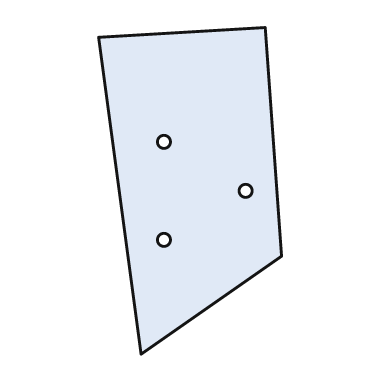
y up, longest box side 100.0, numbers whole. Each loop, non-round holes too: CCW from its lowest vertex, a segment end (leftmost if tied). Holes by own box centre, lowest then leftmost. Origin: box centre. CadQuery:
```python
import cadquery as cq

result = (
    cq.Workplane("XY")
    .moveTo(-15.0, -50.0)
    .lineTo(28.0, -20.0)
    .lineTo(23.0, 50.0)
    .lineTo(-28.0, 47.0)
    .close()
    .moveTo(-8.0, -15.0)
    .circle(2.0)
    .moveTo(17.0, 0.0)
    .circle(2.0)
    .moveTo(-8.0, 15.0)
    .circle(2.0)
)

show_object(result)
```